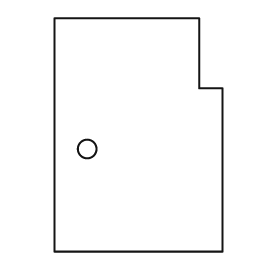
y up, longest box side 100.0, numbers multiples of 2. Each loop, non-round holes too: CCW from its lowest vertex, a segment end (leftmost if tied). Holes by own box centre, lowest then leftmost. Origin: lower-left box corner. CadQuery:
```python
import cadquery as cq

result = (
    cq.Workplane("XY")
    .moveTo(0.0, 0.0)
    .lineTo(72.0, 0.0)
    .lineTo(72.0, 70.0)
    .lineTo(62.0, 70.0)
    .lineTo(62.0, 100.0)
    .lineTo(0.0, 100.0)
    .close()
    .moveTo(14.0, 44.0)
    .circle(4.0)
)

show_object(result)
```